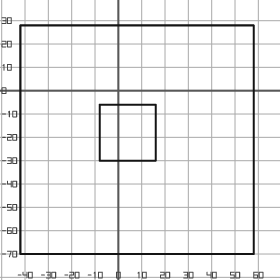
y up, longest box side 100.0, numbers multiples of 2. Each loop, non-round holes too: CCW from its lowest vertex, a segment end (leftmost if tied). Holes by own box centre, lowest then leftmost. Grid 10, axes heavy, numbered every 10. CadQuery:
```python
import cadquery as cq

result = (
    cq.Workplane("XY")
    .moveTo(-42.0, -70.0)
    .lineTo(58.0, -70.0)
    .lineTo(58.0, 28.0)
    .lineTo(-42.0, 28.0)
    .close()
    .moveTo(-8.0, -30.0)
    .lineTo(16.0, -30.0)
    .lineTo(16.0, -6.0)
    .lineTo(-8.0, -6.0)
    .close()
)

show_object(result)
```